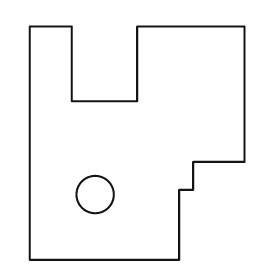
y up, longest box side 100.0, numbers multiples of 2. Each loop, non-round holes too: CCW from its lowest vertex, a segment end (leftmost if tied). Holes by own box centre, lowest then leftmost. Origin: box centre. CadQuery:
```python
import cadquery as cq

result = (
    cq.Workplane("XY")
    .moveTo(-46.0, -50.0)
    .lineTo(18.0, -50.0)
    .lineTo(18.0, -20.0)
    .lineTo(24.0, -20.0)
    .lineTo(24.0, -8.0)
    .lineTo(46.0, -8.0)
    .lineTo(46.0, 50.0)
    .lineTo(0.0, 50.0)
    .lineTo(0.0, 18.0)
    .lineTo(-28.0, 18.0)
    .lineTo(-28.0, 50.0)
    .lineTo(-46.0, 50.0)
    .close()
    .moveTo(-18.0, -22.0)
    .circle(8.0)
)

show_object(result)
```